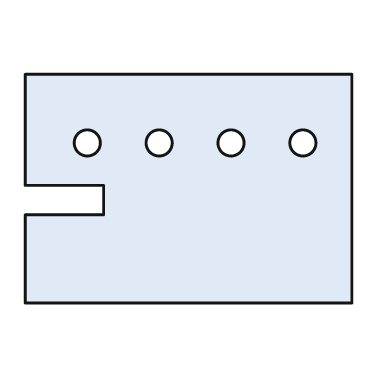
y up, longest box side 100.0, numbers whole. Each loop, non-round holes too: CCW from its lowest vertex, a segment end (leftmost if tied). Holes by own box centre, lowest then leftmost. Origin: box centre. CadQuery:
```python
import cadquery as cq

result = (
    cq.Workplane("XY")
    .moveTo(-50.0, -35.0)
    .lineTo(50.0, -35.0)
    .lineTo(50.0, 35.0)
    .lineTo(-50.0, 35.0)
    .lineTo(-50.0, 1.0)
    .lineTo(-26.0, 1.0)
    .lineTo(-26.0, -8.0)
    .lineTo(-50.0, -8.0)
    .close()
    .moveTo(-31.0, 14.0)
    .circle(4.0)
    .moveTo(-9.0, 14.0)
    .circle(4.0)
    .moveTo(13.0, 14.0)
    .circle(4.0)
    .moveTo(35.0, 14.0)
    .circle(4.0)
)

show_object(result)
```